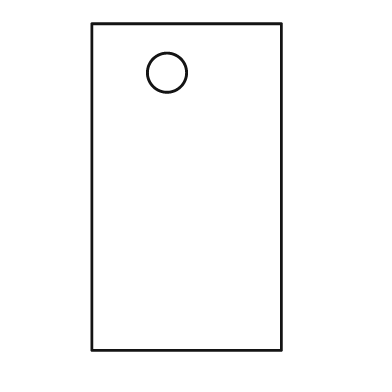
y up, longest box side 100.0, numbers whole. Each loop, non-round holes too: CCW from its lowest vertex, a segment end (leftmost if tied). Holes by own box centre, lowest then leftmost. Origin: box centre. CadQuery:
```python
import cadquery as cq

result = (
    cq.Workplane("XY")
    .moveTo(-29.0, -50.0)
    .lineTo(29.0, -50.0)
    .lineTo(29.0, 50.0)
    .lineTo(-29.0, 50.0)
    .close()
    .moveTo(-6.0, 35.0)
    .circle(6.0)
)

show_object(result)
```